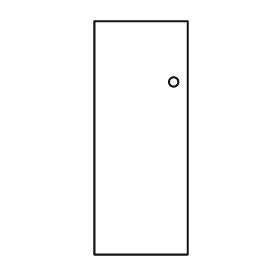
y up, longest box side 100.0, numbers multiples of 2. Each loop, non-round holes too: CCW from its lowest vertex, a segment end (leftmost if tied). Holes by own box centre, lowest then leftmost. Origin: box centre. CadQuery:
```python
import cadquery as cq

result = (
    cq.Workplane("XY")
    .moveTo(-20.0, -50.0)
    .lineTo(20.0, -50.0)
    .lineTo(20.0, 50.0)
    .lineTo(-20.0, 50.0)
    .close()
    .moveTo(14.0, 24.0)
    .circle(2.0)
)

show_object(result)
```